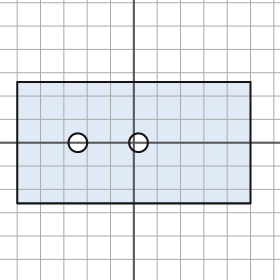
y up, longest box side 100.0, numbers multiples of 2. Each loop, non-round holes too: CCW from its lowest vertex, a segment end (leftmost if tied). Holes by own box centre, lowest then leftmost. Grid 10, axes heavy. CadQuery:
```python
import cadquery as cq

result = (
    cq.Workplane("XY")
    .moveTo(-50.0, -26.0)
    .lineTo(50.0, -26.0)
    .lineTo(50.0, 26.0)
    .lineTo(-50.0, 26.0)
    .close()
    .moveTo(-24.0, 0.0)
    .circle(4.0)
    .moveTo(2.0, 0.0)
    .circle(4.0)
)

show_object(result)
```